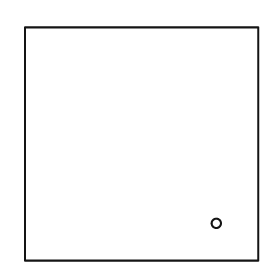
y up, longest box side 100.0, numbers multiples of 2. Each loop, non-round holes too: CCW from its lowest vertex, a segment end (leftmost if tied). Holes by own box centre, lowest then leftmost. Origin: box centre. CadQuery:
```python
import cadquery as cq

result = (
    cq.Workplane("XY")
    .moveTo(-50.0, -50.0)
    .lineTo(50.0, -50.0)
    .lineTo(50.0, 50.0)
    .lineTo(-50.0, 50.0)
    .close()
    .moveTo(32.0, -34.0)
    .circle(2.0)
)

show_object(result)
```